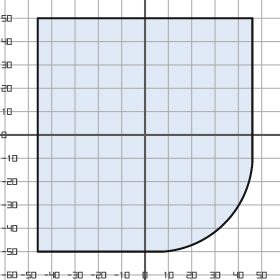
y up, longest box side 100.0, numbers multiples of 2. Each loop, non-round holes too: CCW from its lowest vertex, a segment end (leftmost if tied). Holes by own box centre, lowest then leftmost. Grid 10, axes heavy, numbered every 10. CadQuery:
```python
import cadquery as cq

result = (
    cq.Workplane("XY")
    .moveTo(-46.0, -50.0)
    .lineTo(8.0, -50.0)
    .threePointArc((34.0, -38.0), (46.0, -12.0))
    .lineTo(46.0, 50.0)
    .lineTo(-46.0, 50.0)
    .close()
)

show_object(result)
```